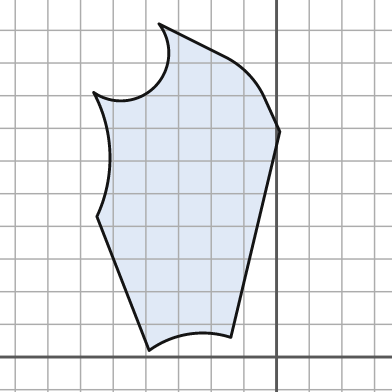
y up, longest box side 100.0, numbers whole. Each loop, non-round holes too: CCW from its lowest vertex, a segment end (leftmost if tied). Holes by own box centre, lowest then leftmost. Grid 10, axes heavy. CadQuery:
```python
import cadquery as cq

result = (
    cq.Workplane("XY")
    .moveTo(-39.0, 2.0)
    .threePointArc((-27.0, 7.0), (-14.0, 6.0))
    .lineTo(1.0, 69.0)
    .lineTo(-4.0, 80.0)
    .threePointArc((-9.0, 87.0), (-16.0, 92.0))
    .lineTo(-36.0, 102.0)
    .threePointArc((-37.0, 83.0), (-56.0, 81.0))
    .threePointArc((-51.0, 62.0), (-55.0, 43.0))
    .close()
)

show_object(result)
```